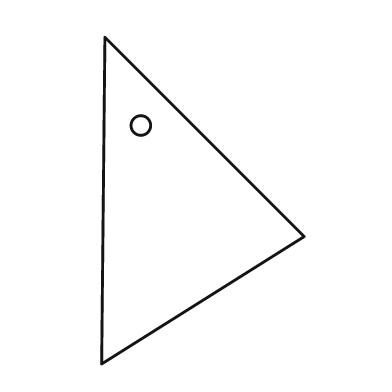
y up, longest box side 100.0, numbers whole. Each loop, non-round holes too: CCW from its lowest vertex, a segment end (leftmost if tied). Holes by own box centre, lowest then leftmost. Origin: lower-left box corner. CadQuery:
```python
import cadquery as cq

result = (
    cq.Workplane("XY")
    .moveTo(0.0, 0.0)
    .lineTo(62.0, 39.0)
    .lineTo(1.0, 100.0)
    .close()
    .moveTo(12.0, 73.0)
    .circle(3.0)
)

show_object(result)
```